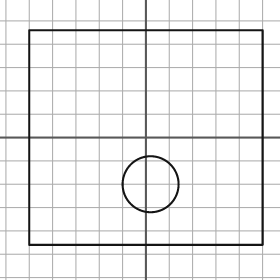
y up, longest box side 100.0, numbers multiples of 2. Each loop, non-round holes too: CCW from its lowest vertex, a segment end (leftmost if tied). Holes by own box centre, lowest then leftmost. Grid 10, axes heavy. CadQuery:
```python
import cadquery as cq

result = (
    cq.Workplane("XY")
    .moveTo(-50.0, -46.0)
    .lineTo(50.0, -46.0)
    .lineTo(50.0, 46.0)
    .lineTo(-50.0, 46.0)
    .close()
    .moveTo(2.0, -20.0)
    .circle(12.0)
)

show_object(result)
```